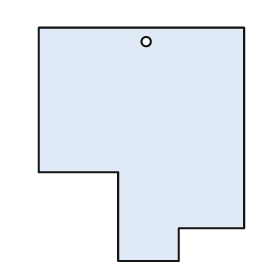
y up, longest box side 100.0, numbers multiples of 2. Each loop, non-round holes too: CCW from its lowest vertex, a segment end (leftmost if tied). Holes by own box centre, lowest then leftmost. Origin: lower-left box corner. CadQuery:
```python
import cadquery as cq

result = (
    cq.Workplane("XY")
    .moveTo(34.0, 0.0)
    .lineTo(60.0, 0.0)
    .lineTo(60.0, 14.0)
    .lineTo(88.0, 14.0)
    .lineTo(88.0, 100.0)
    .lineTo(0.0, 100.0)
    .lineTo(0.0, 38.0)
    .lineTo(34.0, 38.0)
    .close()
    .moveTo(46.0, 94.0)
    .circle(2.0)
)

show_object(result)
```